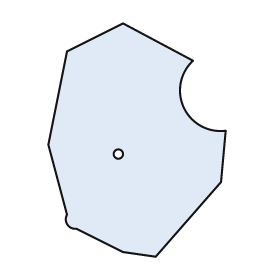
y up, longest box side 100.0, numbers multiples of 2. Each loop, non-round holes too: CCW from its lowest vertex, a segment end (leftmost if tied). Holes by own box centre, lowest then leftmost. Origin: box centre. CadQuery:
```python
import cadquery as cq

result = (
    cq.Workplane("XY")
    .moveTo(8.0, -50.0)
    .lineTo(36.0, -18.0)
    .lineTo(38.0, 4.0)
    .threePointArc((20.0, 14.0), (24.0, 34.0))
    .lineTo(-6.0, 50.0)
    .lineTo(-30.0, 38.0)
    .lineTo(-38.0, -2.0)
    .lineTo(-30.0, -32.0)
    .threePointArc((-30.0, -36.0), (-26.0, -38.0))
    .lineTo(-6.0, -48.0)
    .close()
    .moveTo(-8.0, -6.0)
    .circle(2.0)
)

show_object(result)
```